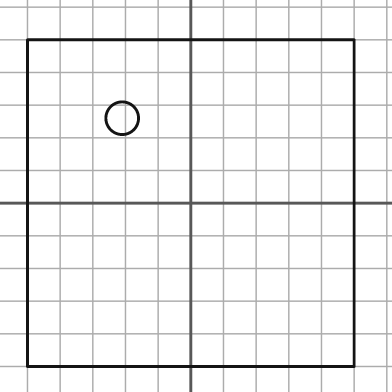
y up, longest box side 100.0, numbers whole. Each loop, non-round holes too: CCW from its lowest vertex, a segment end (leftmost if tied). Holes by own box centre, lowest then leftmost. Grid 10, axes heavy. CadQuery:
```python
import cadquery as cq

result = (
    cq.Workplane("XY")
    .moveTo(-50.0, -50.0)
    .lineTo(50.0, -50.0)
    .lineTo(50.0, 50.0)
    .lineTo(-50.0, 50.0)
    .close()
    .moveTo(-21.0, 26.0)
    .circle(5.0)
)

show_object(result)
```